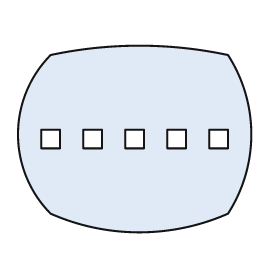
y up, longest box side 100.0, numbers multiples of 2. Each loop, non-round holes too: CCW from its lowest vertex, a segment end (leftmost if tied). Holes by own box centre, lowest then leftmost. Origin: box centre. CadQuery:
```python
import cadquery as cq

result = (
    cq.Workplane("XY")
    .moveTo(-36.0, -32.0)
    .threePointArc((2.0, -40.0), (40.0, -32.0))
    .threePointArc((50.0, 2.0), (40.0, 36.0))
    .threePointArc((2.0, 40.0), (-36.0, 36.0))
    .threePointArc((-50.0, 2.0), (-36.0, -32.0))
    .close()
    .moveTo(-40.0, -4.0)
    .lineTo(-32.0, -4.0)
    .lineTo(-32.0, 4.0)
    .lineTo(-40.0, 4.0)
    .close()
    .moveTo(-22.0, -4.0)
    .lineTo(-14.0, -4.0)
    .lineTo(-14.0, 4.0)
    .lineTo(-22.0, 4.0)
    .close()
    .moveTo(-4.0, -4.0)
    .lineTo(4.0, -4.0)
    .lineTo(4.0, 4.0)
    .lineTo(-4.0, 4.0)
    .close()
    .moveTo(14.0, -4.0)
    .lineTo(22.0, -4.0)
    .lineTo(22.0, 4.0)
    .lineTo(14.0, 4.0)
    .close()
    .moveTo(32.0, -4.0)
    .lineTo(40.0, -4.0)
    .lineTo(40.0, 4.0)
    .lineTo(32.0, 4.0)
    .close()
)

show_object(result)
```